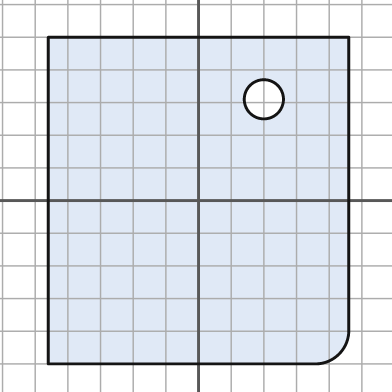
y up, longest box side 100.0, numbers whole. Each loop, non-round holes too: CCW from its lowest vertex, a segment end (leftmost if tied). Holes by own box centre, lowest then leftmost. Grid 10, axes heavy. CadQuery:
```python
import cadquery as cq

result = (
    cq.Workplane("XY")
    .moveTo(-46.0, -50.0)
    .lineTo(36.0, -50.0)
    .threePointArc((43.0, -47.0), (46.0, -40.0))
    .lineTo(46.0, 50.0)
    .lineTo(-46.0, 50.0)
    .close()
    .moveTo(20.0, 31.0)
    .circle(6.0)
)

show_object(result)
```